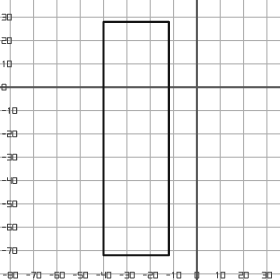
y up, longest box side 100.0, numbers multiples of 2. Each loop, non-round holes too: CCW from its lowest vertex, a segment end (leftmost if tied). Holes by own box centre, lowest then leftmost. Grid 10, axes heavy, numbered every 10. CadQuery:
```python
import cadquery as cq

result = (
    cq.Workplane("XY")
    .moveTo(-40.0, -72.0)
    .lineTo(-12.0, -72.0)
    .lineTo(-12.0, 28.0)
    .lineTo(-40.0, 28.0)
    .close()
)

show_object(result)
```